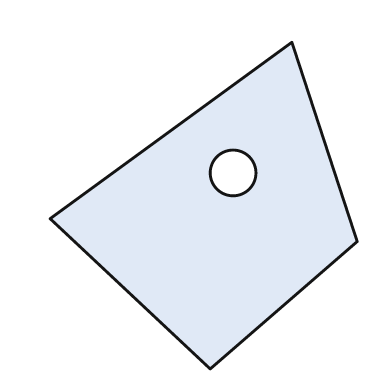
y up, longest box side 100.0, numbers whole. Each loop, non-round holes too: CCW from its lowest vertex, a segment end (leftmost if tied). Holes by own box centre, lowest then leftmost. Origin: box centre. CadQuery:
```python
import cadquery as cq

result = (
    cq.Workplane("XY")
    .moveTo(2.0, -50.0)
    .lineTo(47.0, -11.0)
    .lineTo(27.0, 50.0)
    .lineTo(-47.0, -4.0)
    .close()
    .moveTo(9.0, 10.0)
    .circle(7.0)
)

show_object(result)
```